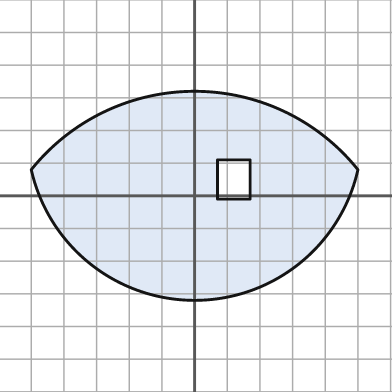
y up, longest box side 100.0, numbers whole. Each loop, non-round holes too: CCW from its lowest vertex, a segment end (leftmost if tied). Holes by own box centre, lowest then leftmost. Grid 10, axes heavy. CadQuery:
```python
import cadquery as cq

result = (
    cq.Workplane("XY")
    .moveTo(-50.0, 8.0)
    .threePointArc((0.0, -32.0), (50.0, 8.0))
    .threePointArc((0.0, 32.0), (-50.0, 8.0))
    .close()
    .moveTo(7.0, -1.0)
    .lineTo(17.0, -1.0)
    .lineTo(17.0, 11.0)
    .lineTo(7.0, 11.0)
    .close()
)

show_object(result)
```